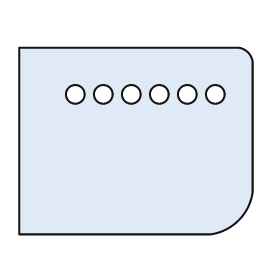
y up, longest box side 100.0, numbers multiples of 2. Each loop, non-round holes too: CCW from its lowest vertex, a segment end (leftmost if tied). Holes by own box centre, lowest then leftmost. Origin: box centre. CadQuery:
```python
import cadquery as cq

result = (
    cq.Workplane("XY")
    .moveTo(-50.0, -40.0)
    .lineTo(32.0, -40.0)
    .threePointArc((44.0, -34.0), (50.0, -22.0))
    .lineTo(50.0, 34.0)
    .threePointArc((48.0, 38.0), (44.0, 40.0))
    .lineTo(-50.0, 40.0)
    .close()
    .moveTo(-26.0, 20.0)
    .circle(4.0)
    .moveTo(-14.0, 20.0)
    .circle(4.0)
    .moveTo(-2.0, 20.0)
    .circle(4.0)
    .moveTo(10.0, 20.0)
    .circle(4.0)
    .moveTo(22.0, 20.0)
    .circle(4.0)
    .moveTo(34.0, 20.0)
    .circle(4.0)
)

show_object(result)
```